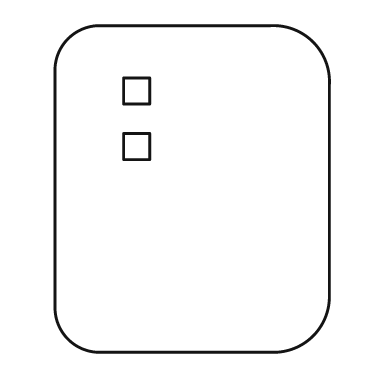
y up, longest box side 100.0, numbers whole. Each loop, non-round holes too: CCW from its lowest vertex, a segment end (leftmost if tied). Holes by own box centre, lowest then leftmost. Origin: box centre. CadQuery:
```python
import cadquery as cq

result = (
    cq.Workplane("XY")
    .moveTo(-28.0, -50.0)
    .lineTo(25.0, -50.0)
    .threePointArc((37.0, -45.0), (42.0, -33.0))
    .lineTo(42.0, 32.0)
    .threePointArc((37.0, 45.0), (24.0, 50.0))
    .lineTo(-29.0, 50.0)
    .threePointArc((-38.0, 46.0), (-42.0, 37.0))
    .lineTo(-42.0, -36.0)
    .threePointArc((-38.0, -46.0), (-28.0, -50.0))
    .close()
    .moveTo(-21.0, 9.0)
    .lineTo(-13.0, 9.0)
    .lineTo(-13.0, 17.0)
    .lineTo(-21.0, 17.0)
    .close()
    .moveTo(-21.0, 26.0)
    .lineTo(-13.0, 26.0)
    .lineTo(-13.0, 34.0)
    .lineTo(-21.0, 34.0)
    .close()
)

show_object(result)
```